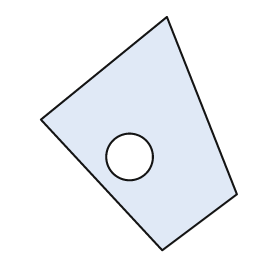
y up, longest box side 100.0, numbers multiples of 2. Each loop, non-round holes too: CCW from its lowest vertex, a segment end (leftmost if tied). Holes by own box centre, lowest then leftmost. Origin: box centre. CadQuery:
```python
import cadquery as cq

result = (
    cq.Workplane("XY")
    .moveTo(10.0, -50.0)
    .lineTo(42.0, -26.0)
    .lineTo(12.0, 50.0)
    .lineTo(-42.0, 6.0)
    .close()
    .moveTo(-4.0, -10.0)
    .circle(10.0)
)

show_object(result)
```